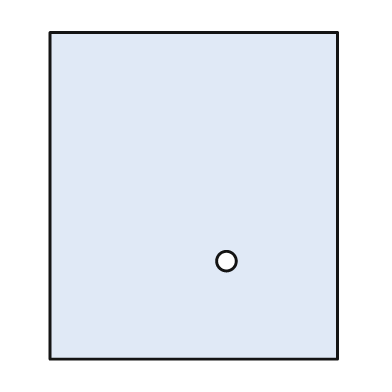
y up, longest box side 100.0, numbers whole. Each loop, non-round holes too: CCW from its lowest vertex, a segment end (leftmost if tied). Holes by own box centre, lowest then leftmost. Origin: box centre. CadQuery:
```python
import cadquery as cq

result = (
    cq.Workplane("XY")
    .moveTo(-44.0, -50.0)
    .lineTo(44.0, -50.0)
    .lineTo(44.0, 50.0)
    .lineTo(-44.0, 50.0)
    .close()
    .moveTo(10.0, -20.0)
    .circle(3.0)
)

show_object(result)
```